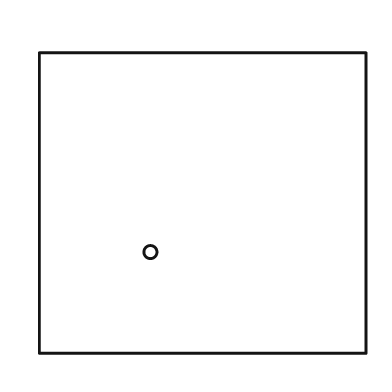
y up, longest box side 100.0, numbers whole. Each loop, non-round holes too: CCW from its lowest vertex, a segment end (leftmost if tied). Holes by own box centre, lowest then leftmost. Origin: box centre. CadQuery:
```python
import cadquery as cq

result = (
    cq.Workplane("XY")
    .moveTo(-50.0, -46.0)
    .lineTo(50.0, -46.0)
    .lineTo(50.0, 46.0)
    .lineTo(-50.0, 46.0)
    .close()
    .moveTo(-16.0, -15.0)
    .circle(2.0)
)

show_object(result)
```